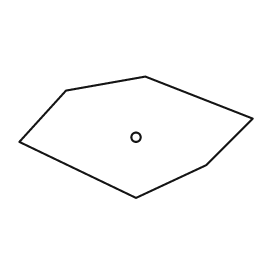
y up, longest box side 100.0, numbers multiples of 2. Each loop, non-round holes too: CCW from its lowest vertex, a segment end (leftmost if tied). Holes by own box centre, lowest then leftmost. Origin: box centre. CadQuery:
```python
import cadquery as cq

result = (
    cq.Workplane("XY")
    .moveTo(0.0, -26.0)
    .lineTo(30.0, -12.0)
    .lineTo(50.0, 8.0)
    .lineTo(4.0, 26.0)
    .lineTo(-30.0, 20.0)
    .lineTo(-50.0, -2.0)
    .close()
    .moveTo(0.0, 0.0)
    .circle(2.0)
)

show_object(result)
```